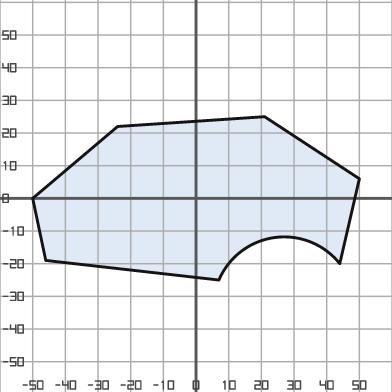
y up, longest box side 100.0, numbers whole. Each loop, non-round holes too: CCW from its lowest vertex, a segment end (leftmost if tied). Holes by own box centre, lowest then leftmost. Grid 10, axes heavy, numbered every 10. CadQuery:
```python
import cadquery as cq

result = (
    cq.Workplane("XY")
    .moveTo(7.0, -25.0)
    .threePointArc((24.0, -12.0), (44.0, -20.0))
    .lineTo(50.0, 6.0)
    .lineTo(21.0, 25.0)
    .lineTo(-24.0, 22.0)
    .lineTo(-50.0, 0.0)
    .lineTo(-46.0, -19.0)
    .close()
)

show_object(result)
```